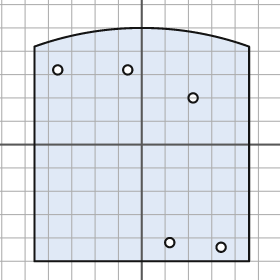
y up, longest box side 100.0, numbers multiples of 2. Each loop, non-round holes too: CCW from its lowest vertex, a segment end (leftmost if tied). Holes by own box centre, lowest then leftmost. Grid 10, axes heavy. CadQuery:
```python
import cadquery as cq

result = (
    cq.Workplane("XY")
    .moveTo(-46.0, -50.0)
    .lineTo(46.0, -50.0)
    .lineTo(46.0, 42.0)
    .threePointArc((0.0, 50.0), (-46.0, 42.0))
    .close()
    .moveTo(34.0, -44.0)
    .circle(2.0)
    .moveTo(12.0, -42.0)
    .circle(2.0)
    .moveTo(22.0, 20.0)
    .circle(2.0)
    .moveTo(-36.0, 32.0)
    .circle(2.0)
    .moveTo(-6.0, 32.0)
    .circle(2.0)
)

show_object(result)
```